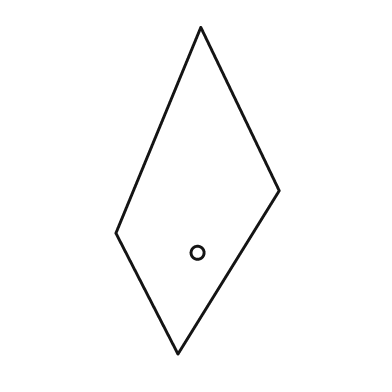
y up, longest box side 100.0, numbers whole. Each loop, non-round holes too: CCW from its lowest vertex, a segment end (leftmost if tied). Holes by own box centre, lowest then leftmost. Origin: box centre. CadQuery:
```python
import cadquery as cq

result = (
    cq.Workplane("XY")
    .moveTo(-6.0, -50.0)
    .lineTo(25.0, 0.0)
    .lineTo(1.0, 50.0)
    .lineTo(-25.0, -13.0)
    .close()
    .moveTo(0.0, -19.0)
    .circle(2.0)
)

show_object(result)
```